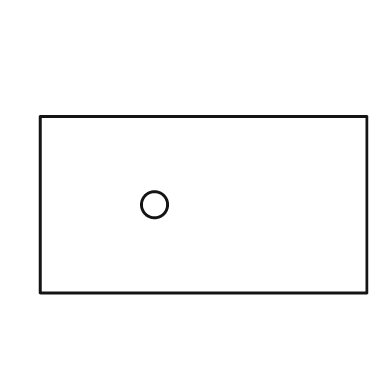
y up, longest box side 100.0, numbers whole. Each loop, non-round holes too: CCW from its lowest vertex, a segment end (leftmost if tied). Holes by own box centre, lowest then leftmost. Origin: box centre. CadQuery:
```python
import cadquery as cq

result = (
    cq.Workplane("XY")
    .moveTo(-50.0, -27.0)
    .lineTo(50.0, -27.0)
    .lineTo(50.0, 27.0)
    .lineTo(-50.0, 27.0)
    .close()
    .moveTo(-15.0, 0.0)
    .circle(4.0)
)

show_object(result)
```